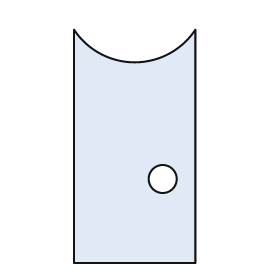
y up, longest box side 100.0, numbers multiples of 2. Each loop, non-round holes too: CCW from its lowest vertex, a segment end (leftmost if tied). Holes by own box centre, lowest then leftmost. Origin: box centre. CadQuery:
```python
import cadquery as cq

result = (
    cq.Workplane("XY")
    .moveTo(-26.0, -50.0)
    .lineTo(26.0, -50.0)
    .lineTo(26.0, 50.0)
    .threePointArc((0.0, 36.0), (-26.0, 50.0))
    .close()
    .moveTo(12.0, -14.0)
    .circle(6.0)
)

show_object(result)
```